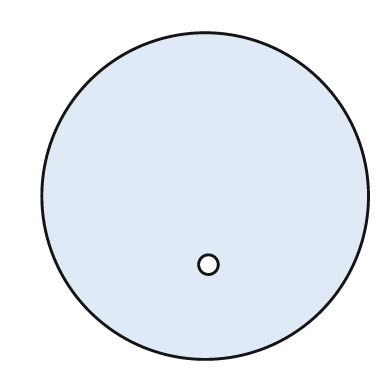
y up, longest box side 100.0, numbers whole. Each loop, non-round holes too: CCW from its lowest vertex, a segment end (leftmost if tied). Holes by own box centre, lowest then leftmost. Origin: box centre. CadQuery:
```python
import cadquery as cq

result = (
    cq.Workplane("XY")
    .moveTo(0.0, 0.0)
    .circle(50.0)
    .moveTo(1.0, -21.0)
    .circle(3.0)
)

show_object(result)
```